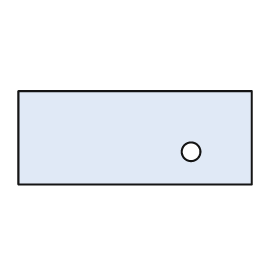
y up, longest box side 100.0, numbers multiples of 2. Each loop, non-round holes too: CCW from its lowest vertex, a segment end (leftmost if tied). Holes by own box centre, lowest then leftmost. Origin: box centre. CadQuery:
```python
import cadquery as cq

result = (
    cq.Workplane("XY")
    .moveTo(-50.0, -20.0)
    .lineTo(50.0, -20.0)
    .lineTo(50.0, 20.0)
    .lineTo(-50.0, 20.0)
    .close()
    .moveTo(24.0, -6.0)
    .circle(4.0)
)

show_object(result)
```